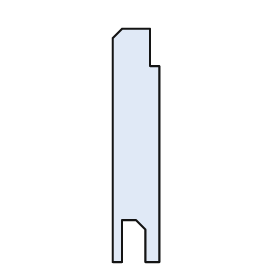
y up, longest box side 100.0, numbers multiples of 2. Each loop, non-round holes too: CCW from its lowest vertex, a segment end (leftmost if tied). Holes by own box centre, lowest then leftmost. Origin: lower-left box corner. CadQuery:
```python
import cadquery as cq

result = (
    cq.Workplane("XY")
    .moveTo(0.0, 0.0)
    .lineTo(4.0, 0.0)
    .lineTo(4.0, 18.0)
    .lineTo(10.0, 18.0)
    .lineTo(14.0, 14.0)
    .lineTo(14.0, 0.0)
    .lineTo(20.0, 0.0)
    .lineTo(20.0, 84.0)
    .lineTo(16.0, 84.0)
    .lineTo(16.0, 100.0)
    .lineTo(4.0, 100.0)
    .lineTo(0.0, 96.0)
    .close()
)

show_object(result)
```